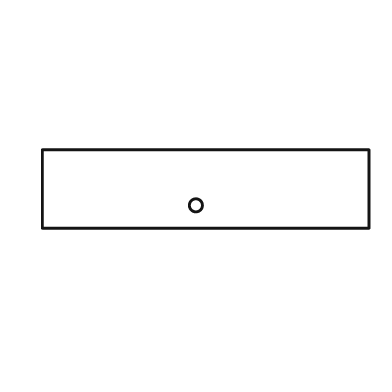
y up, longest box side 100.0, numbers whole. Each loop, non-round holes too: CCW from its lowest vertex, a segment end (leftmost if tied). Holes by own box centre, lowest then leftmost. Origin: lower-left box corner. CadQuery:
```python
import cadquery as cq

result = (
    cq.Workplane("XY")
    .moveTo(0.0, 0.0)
    .lineTo(100.0, 0.0)
    .lineTo(100.0, 24.0)
    .lineTo(0.0, 24.0)
    .close()
    .moveTo(47.0, 7.0)
    .circle(2.0)
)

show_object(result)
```